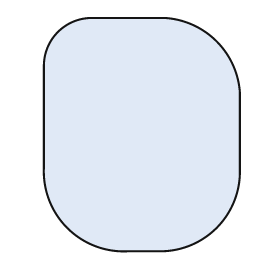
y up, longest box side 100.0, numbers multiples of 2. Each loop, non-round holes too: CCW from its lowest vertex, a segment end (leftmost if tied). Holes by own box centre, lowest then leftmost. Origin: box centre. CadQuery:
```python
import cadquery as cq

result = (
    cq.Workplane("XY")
    .moveTo(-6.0, -50.0)
    .lineTo(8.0, -50.0)
    .threePointArc((32.0, -40.0), (42.0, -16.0))
    .lineTo(42.0, 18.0)
    .threePointArc((32.0, 40.0), (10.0, 50.0))
    .lineTo(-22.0, 50.0)
    .threePointArc((-36.0, 44.0), (-42.0, 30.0))
    .lineTo(-42.0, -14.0)
    .threePointArc((-32.0, -40.0), (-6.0, -50.0))
    .close()
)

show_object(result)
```